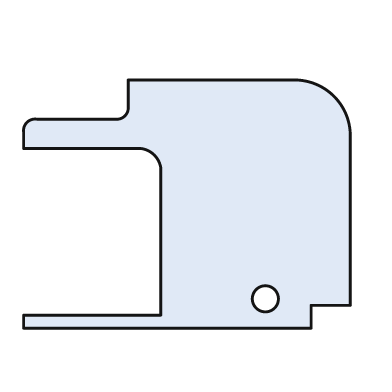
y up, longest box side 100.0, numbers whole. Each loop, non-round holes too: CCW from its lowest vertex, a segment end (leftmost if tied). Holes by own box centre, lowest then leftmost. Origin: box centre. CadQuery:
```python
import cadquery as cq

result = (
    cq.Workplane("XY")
    .moveTo(-50.0, -38.0)
    .lineTo(38.0, -38.0)
    .lineTo(38.0, -31.0)
    .lineTo(50.0, -31.0)
    .lineTo(50.0, 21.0)
    .threePointArc((45.0, 33.0), (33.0, 38.0))
    .lineTo(-18.0, 38.0)
    .lineTo(-18.0, 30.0)
    .threePointArc((-19.0, 27.0), (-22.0, 26.0))
    .lineTo(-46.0, 26.0)
    .threePointArc((-49.0, 25.0), (-50.0, 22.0))
    .lineTo(-50.0, 17.0)
    .lineTo(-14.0, 17.0)
    .threePointArc((-10.0, 15.0), (-8.0, 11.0))
    .lineTo(-8.0, -34.0)
    .lineTo(-50.0, -34.0)
    .close()
    .moveTo(24.0, -29.0)
    .circle(4.0)
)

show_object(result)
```